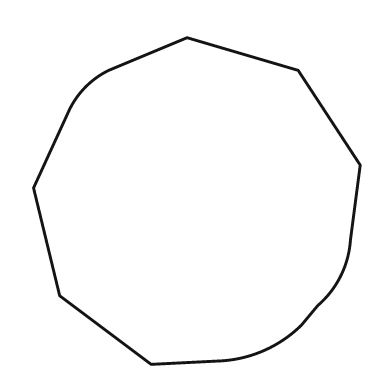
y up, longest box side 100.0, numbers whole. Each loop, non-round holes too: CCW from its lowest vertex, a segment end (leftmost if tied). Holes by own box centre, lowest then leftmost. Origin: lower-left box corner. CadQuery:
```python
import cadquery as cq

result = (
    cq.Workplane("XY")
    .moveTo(36.0, 0.0)
    .lineTo(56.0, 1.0)
    .threePointArc((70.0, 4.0), (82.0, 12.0))
    .lineTo(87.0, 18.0)
    .threePointArc((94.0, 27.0), (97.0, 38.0))
    .lineTo(100.0, 61.0)
    .lineTo(81.0, 90.0)
    .lineTo(47.0, 100.0)
    .lineTo(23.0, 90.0)
    .threePointArc((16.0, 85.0), (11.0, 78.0))
    .lineTo(0.0, 54.0)
    .lineTo(8.0, 21.0)
    .close()
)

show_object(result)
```